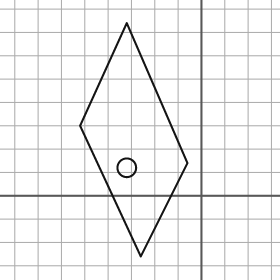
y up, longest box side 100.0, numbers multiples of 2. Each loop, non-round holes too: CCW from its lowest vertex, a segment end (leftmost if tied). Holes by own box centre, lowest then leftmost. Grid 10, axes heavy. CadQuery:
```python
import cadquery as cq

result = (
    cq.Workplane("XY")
    .moveTo(-26.0, -26.0)
    .lineTo(-6.0, 14.0)
    .lineTo(-32.0, 74.0)
    .lineTo(-52.0, 30.0)
    .close()
    .moveTo(-32.0, 12.0)
    .circle(4.0)
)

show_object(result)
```